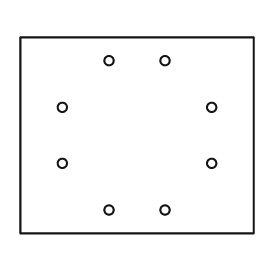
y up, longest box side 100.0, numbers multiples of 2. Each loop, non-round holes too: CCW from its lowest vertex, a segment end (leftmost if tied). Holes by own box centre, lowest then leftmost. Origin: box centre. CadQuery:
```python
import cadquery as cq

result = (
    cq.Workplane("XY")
    .moveTo(-50.0, -42.0)
    .lineTo(50.0, -42.0)
    .lineTo(50.0, 42.0)
    .lineTo(-50.0, 42.0)
    .close()
    .moveTo(-12.0, -32.0)
    .circle(2.0)
    .moveTo(12.0, -32.0)
    .circle(2.0)
    .moveTo(-32.0, -12.0)
    .circle(2.0)
    .moveTo(32.0, -12.0)
    .circle(2.0)
    .moveTo(-32.0, 12.0)
    .circle(2.0)
    .moveTo(32.0, 12.0)
    .circle(2.0)
    .moveTo(-12.0, 32.0)
    .circle(2.0)
    .moveTo(12.0, 32.0)
    .circle(2.0)
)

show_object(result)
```